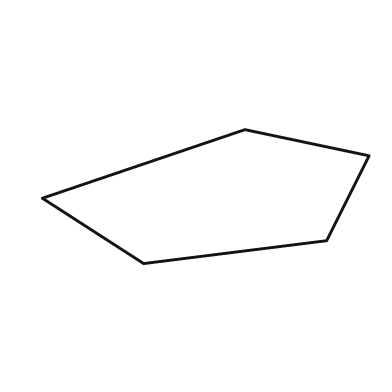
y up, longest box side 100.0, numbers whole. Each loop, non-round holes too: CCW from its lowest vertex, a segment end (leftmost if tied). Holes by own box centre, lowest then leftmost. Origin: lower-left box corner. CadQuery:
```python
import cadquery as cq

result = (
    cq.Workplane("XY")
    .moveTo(31.0, 0.0)
    .lineTo(87.0, 7.0)
    .lineTo(100.0, 33.0)
    .lineTo(62.0, 41.0)
    .lineTo(0.0, 20.0)
    .close()
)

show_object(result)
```